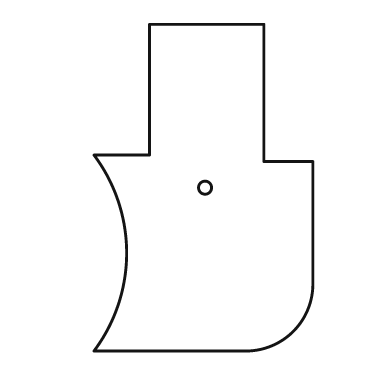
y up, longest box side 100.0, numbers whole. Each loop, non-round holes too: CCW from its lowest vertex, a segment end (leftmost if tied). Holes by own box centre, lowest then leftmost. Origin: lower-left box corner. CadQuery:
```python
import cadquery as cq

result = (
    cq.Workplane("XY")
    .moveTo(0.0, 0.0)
    .lineTo(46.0, 0.0)
    .threePointArc((61.0, 6.0), (67.0, 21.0))
    .lineTo(67.0, 58.0)
    .lineTo(52.0, 58.0)
    .lineTo(52.0, 100.0)
    .lineTo(17.0, 100.0)
    .lineTo(17.0, 60.0)
    .lineTo(0.0, 60.0)
    .threePointArc((10.0, 30.0), (0.0, 0.0))
    .close()
    .moveTo(34.0, 50.0)
    .circle(2.0)
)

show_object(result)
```